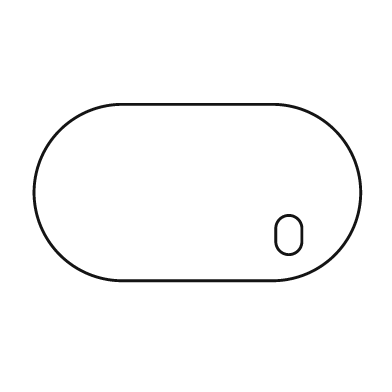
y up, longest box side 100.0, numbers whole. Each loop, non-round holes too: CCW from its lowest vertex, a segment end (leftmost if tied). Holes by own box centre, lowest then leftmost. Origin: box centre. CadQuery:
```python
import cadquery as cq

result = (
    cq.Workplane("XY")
    .moveTo(-23.0, -27.0)
    .lineTo(23.0, -27.0)
    .threePointArc((50.0, 0.0), (23.0, 27.0))
    .lineTo(-23.0, 27.0)
    .threePointArc((-50.0, 0.0), (-23.0, -27.0))
    .close()
    .moveTo(24.0, -15.0)
    .threePointArc((28.0, -19.0), (32.0, -15.0))
    .lineTo(32.0, -11.0)
    .threePointArc((28.0, -7.0), (24.0, -11.0))
    .close()
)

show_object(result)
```